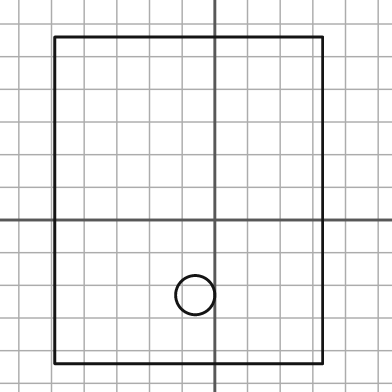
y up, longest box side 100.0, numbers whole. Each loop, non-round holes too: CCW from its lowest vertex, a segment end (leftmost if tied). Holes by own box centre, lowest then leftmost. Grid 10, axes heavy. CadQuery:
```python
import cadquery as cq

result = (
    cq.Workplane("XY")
    .moveTo(-49.0, -44.0)
    .lineTo(33.0, -44.0)
    .lineTo(33.0, 56.0)
    .lineTo(-49.0, 56.0)
    .close()
    .moveTo(-6.0, -23.0)
    .circle(6.0)
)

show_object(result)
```